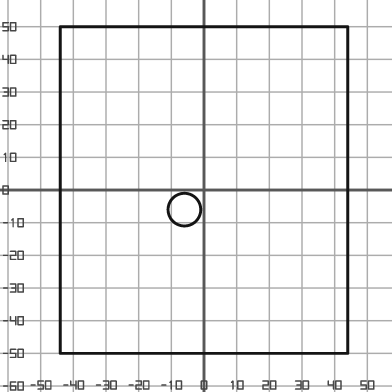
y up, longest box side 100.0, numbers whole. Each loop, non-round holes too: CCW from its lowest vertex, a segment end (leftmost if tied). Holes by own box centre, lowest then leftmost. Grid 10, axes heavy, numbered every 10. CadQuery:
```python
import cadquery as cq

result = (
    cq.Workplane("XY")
    .moveTo(-44.0, -50.0)
    .lineTo(44.0, -50.0)
    .lineTo(44.0, 50.0)
    .lineTo(-44.0, 50.0)
    .close()
    .moveTo(-6.0, -6.0)
    .circle(5.0)
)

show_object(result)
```